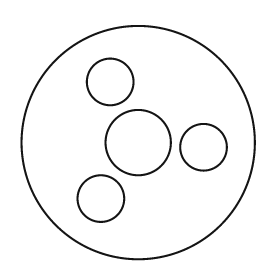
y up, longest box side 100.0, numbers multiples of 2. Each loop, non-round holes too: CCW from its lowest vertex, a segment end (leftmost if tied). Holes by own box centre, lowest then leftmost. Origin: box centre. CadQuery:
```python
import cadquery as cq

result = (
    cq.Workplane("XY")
    .moveTo(0.0, 0.0)
    .circle(50.0)
    .moveTo(-16.0, -24.0)
    .circle(10.0)
    .moveTo(28.0, -2.0)
    .circle(10.0)
    .moveTo(0.0, 0.0)
    .circle(14.0)
    .moveTo(-12.0, 26.0)
    .circle(10.0)
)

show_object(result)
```